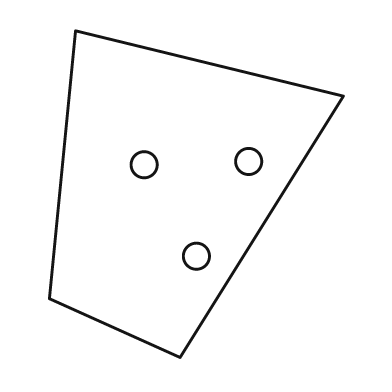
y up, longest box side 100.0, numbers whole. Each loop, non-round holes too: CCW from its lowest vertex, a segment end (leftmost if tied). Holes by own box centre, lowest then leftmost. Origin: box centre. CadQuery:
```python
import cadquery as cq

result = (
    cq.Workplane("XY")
    .moveTo(-5.0, -50.0)
    .lineTo(45.0, 30.0)
    .lineTo(-37.0, 50.0)
    .lineTo(-45.0, -32.0)
    .close()
    .moveTo(0.0, -19.0)
    .circle(4.0)
    .moveTo(-16.0, 9.0)
    .circle(4.0)
    .moveTo(16.0, 10.0)
    .circle(4.0)
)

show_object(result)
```